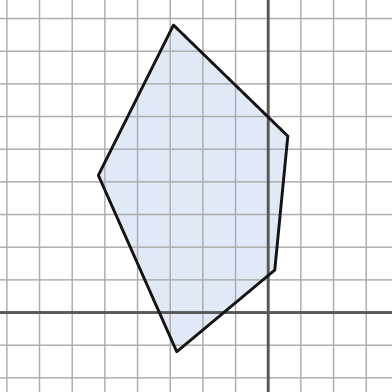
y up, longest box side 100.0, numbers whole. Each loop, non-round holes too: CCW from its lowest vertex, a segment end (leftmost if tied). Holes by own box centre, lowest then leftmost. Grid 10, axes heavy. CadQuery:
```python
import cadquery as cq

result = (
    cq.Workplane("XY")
    .moveTo(-28.0, -12.0)
    .lineTo(2.0, 13.0)
    .lineTo(6.0, 54.0)
    .lineTo(-29.0, 88.0)
    .lineTo(-52.0, 42.0)
    .close()
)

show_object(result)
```